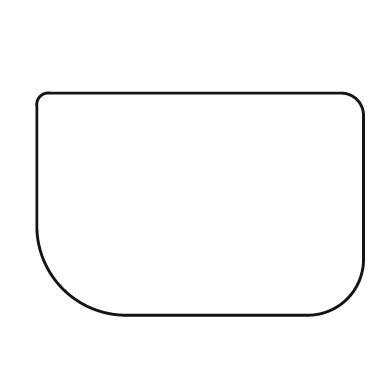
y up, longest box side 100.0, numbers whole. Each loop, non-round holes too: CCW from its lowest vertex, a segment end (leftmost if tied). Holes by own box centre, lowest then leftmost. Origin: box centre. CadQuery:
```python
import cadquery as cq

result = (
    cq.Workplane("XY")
    .moveTo(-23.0, -34.0)
    .lineTo(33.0, -34.0)
    .threePointArc((45.0, -29.0), (50.0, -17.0))
    .lineTo(50.0, 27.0)
    .threePointArc((48.0, 32.0), (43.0, 34.0))
    .lineTo(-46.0, 34.0)
    .threePointArc((-49.0, 33.0), (-50.0, 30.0))
    .lineTo(-50.0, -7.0)
    .threePointArc((-42.0, -26.0), (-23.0, -34.0))
    .close()
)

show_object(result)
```